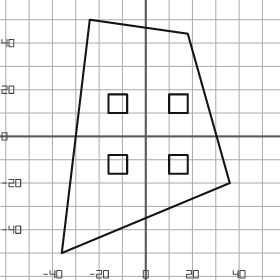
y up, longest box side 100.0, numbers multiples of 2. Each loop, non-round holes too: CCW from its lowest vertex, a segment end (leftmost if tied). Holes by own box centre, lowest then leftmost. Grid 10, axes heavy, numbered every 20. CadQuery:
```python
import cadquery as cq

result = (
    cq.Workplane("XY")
    .moveTo(-36.0, -50.0)
    .lineTo(36.0, -20.0)
    .lineTo(18.0, 44.0)
    .lineTo(-24.0, 50.0)
    .close()
    .moveTo(-16.0, -16.0)
    .lineTo(-8.0, -16.0)
    .lineTo(-8.0, -8.0)
    .lineTo(-16.0, -8.0)
    .close()
    .moveTo(10.0, -16.0)
    .lineTo(18.0, -16.0)
    .lineTo(18.0, -8.0)
    .lineTo(10.0, -8.0)
    .close()
    .moveTo(-16.0, 10.0)
    .lineTo(-8.0, 10.0)
    .lineTo(-8.0, 18.0)
    .lineTo(-16.0, 18.0)
    .close()
    .moveTo(10.0, 10.0)
    .lineTo(18.0, 10.0)
    .lineTo(18.0, 18.0)
    .lineTo(10.0, 18.0)
    .close()
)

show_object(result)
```